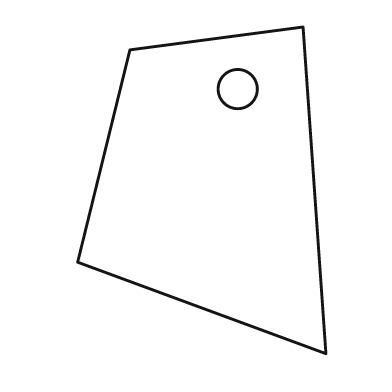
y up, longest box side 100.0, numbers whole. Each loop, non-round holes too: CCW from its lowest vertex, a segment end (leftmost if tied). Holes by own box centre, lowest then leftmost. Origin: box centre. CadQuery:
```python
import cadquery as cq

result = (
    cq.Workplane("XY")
    .moveTo(38.0, -50.0)
    .lineTo(31.0, 50.0)
    .lineTo(-22.0, 43.0)
    .lineTo(-38.0, -22.0)
    .close()
    .moveTo(11.0, 31.0)
    .circle(6.0)
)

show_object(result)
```